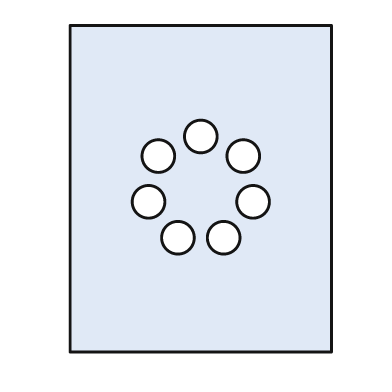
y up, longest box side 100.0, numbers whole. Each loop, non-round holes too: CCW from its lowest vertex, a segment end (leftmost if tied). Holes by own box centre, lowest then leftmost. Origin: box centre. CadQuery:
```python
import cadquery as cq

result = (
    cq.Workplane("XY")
    .moveTo(-40.0, -50.0)
    .lineTo(40.0, -50.0)
    .lineTo(40.0, 50.0)
    .lineTo(-40.0, 50.0)
    .close()
    .moveTo(-7.0, -15.0)
    .circle(5.0)
    .moveTo(7.0, -15.0)
    .circle(5.0)
    .moveTo(-16.0, -4.0)
    .circle(5.0)
    .moveTo(16.0, -4.0)
    .circle(5.0)
    .moveTo(-13.0, 10.0)
    .circle(5.0)
    .moveTo(13.0, 10.0)
    .circle(5.0)
    .moveTo(0.0, 16.0)
    .circle(5.0)
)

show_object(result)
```